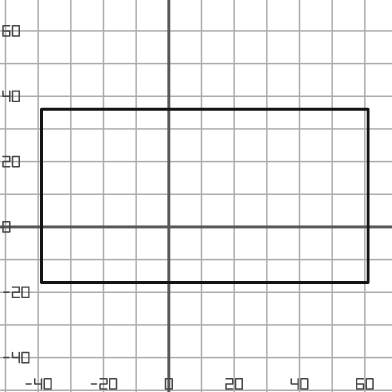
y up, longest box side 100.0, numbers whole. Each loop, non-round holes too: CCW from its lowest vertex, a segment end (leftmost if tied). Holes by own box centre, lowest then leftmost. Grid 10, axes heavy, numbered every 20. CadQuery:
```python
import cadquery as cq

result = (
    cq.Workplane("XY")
    .moveTo(-39.0, -17.0)
    .lineTo(61.0, -17.0)
    .lineTo(61.0, 36.0)
    .lineTo(-39.0, 36.0)
    .close()
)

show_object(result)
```